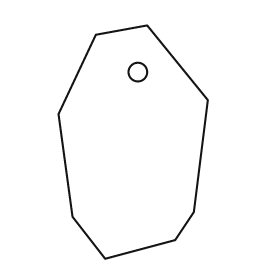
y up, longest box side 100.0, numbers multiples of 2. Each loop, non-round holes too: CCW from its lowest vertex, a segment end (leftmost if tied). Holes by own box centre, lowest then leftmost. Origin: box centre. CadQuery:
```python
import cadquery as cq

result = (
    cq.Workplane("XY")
    .moveTo(-12.0, -50.0)
    .lineTo(18.0, -42.0)
    .lineTo(26.0, -30.0)
    .lineTo(32.0, 18.0)
    .lineTo(6.0, 50.0)
    .lineTo(-16.0, 46.0)
    .lineTo(-32.0, 12.0)
    .lineTo(-26.0, -32.0)
    .close()
    .moveTo(2.0, 30.0)
    .circle(4.0)
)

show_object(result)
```